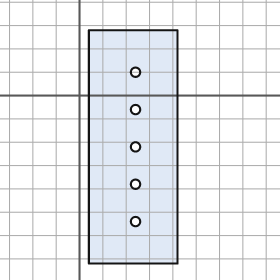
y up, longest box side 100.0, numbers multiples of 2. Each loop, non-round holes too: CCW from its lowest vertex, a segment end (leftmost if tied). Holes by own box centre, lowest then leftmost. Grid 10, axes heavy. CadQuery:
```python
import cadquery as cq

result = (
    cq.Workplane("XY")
    .moveTo(4.0, -72.0)
    .lineTo(42.0, -72.0)
    .lineTo(42.0, 28.0)
    .lineTo(4.0, 28.0)
    .close()
    .moveTo(24.0, -54.0)
    .circle(2.0)
    .moveTo(24.0, -38.0)
    .circle(2.0)
    .moveTo(24.0, -22.0)
    .circle(2.0)
    .moveTo(24.0, -6.0)
    .circle(2.0)
    .moveTo(24.0, 10.0)
    .circle(2.0)
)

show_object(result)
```